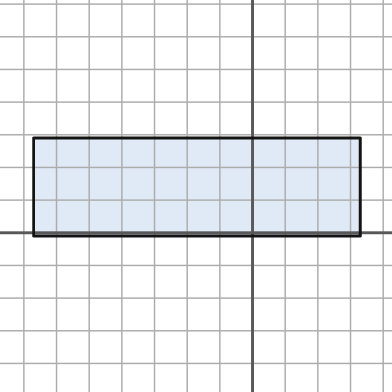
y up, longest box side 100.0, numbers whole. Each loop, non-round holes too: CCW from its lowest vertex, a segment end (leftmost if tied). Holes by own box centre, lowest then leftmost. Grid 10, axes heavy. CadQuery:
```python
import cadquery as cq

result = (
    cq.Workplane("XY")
    .moveTo(-67.0, -1.0)
    .lineTo(33.0, -1.0)
    .lineTo(33.0, 29.0)
    .lineTo(-67.0, 29.0)
    .close()
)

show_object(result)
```